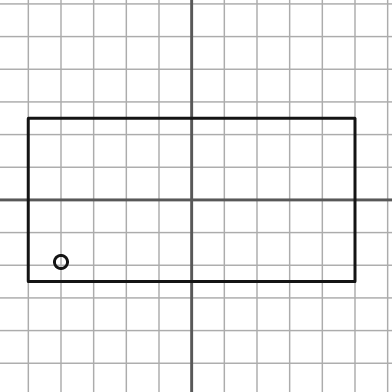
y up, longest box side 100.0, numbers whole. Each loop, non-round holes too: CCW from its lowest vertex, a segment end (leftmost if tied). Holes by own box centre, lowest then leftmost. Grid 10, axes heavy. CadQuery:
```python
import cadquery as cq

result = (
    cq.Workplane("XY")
    .moveTo(-50.0, -25.0)
    .lineTo(50.0, -25.0)
    .lineTo(50.0, 25.0)
    .lineTo(-50.0, 25.0)
    .close()
    .moveTo(-40.0, -19.0)
    .circle(2.0)
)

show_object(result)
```